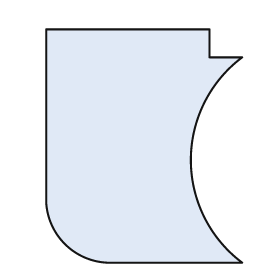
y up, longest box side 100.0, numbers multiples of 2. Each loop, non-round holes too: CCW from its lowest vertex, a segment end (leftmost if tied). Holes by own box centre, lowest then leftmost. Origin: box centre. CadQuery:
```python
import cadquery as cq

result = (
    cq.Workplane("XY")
    .moveTo(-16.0, -50.0)
    .lineTo(42.0, -50.0)
    .threePointArc((20.0, -6.0), (42.0, 38.0))
    .lineTo(28.0, 38.0)
    .lineTo(28.0, 50.0)
    .lineTo(-42.0, 50.0)
    .lineTo(-42.0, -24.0)
    .threePointArc((-34.0, -42.0), (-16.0, -50.0))
    .close()
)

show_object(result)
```